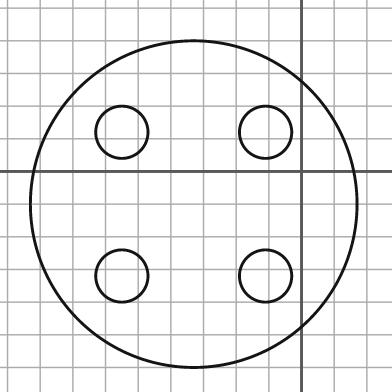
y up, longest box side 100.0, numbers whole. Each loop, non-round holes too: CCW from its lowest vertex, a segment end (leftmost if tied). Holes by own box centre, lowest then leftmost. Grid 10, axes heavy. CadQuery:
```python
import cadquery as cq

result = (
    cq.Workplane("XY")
    .moveTo(-33.0, -10.0)
    .circle(50.0)
    .moveTo(-55.0, -32.0)
    .circle(8.0)
    .moveTo(-11.0, -32.0)
    .circle(8.0)
    .moveTo(-55.0, 12.0)
    .circle(8.0)
    .moveTo(-11.0, 12.0)
    .circle(8.0)
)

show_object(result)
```